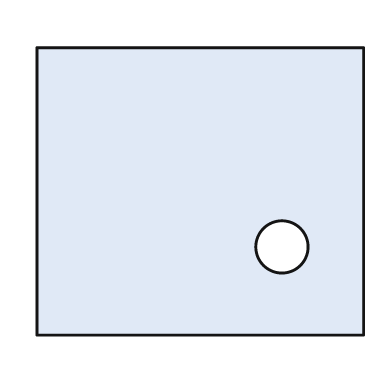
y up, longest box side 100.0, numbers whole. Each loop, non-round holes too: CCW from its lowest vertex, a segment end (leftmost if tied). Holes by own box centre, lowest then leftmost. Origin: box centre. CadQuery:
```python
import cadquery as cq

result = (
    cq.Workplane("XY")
    .moveTo(-50.0, -44.0)
    .lineTo(50.0, -44.0)
    .lineTo(50.0, 44.0)
    .lineTo(-50.0, 44.0)
    .close()
    .moveTo(25.0, -17.0)
    .circle(8.0)
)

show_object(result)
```